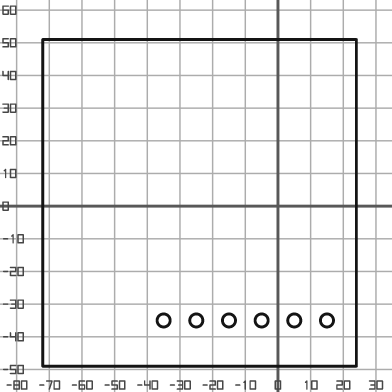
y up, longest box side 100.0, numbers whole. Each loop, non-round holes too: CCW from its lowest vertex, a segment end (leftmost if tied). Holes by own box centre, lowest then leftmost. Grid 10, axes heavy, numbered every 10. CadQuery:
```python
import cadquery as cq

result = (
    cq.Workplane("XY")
    .moveTo(-72.0, -49.0)
    .lineTo(24.0, -49.0)
    .lineTo(24.0, 51.0)
    .lineTo(-72.0, 51.0)
    .close()
    .moveTo(-35.0, -35.0)
    .circle(2.0)
    .moveTo(-25.0, -35.0)
    .circle(2.0)
    .moveTo(-15.0, -35.0)
    .circle(2.0)
    .moveTo(-5.0, -35.0)
    .circle(2.0)
    .moveTo(5.0, -35.0)
    .circle(2.0)
    .moveTo(15.0, -35.0)
    .circle(2.0)
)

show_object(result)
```